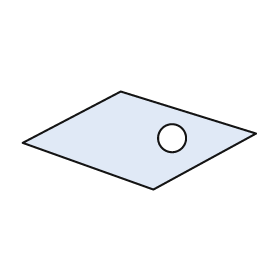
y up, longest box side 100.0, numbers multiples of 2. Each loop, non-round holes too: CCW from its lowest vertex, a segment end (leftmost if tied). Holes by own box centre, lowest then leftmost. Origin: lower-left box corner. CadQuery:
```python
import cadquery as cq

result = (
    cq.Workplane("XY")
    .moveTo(56.0, 0.0)
    .lineTo(100.0, 24.0)
    .lineTo(42.0, 42.0)
    .lineTo(0.0, 20.0)
    .close()
    .moveTo(64.0, 22.0)
    .circle(6.0)
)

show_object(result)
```